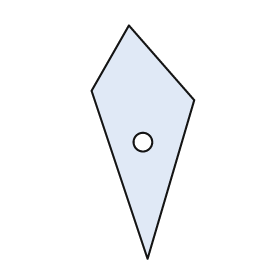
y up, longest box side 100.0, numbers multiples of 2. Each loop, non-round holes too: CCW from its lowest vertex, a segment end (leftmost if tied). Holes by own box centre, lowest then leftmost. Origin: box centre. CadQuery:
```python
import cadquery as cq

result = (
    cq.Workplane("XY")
    .moveTo(2.0, -50.0)
    .lineTo(22.0, 18.0)
    .lineTo(-6.0, 50.0)
    .lineTo(-22.0, 22.0)
    .close()
    .moveTo(0.0, 0.0)
    .circle(4.0)
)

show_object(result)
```